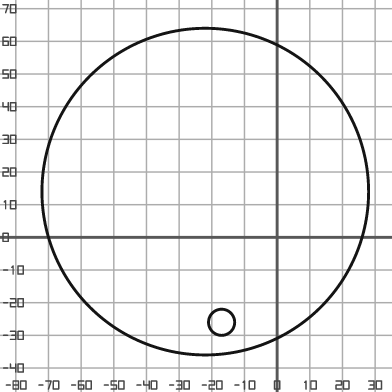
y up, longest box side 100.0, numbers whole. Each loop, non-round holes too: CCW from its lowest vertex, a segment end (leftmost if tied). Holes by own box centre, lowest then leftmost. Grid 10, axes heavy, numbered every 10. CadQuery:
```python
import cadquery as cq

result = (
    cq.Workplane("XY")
    .moveTo(-22.0, 14.0)
    .circle(50.0)
    .moveTo(-17.0, -26.0)
    .circle(4.0)
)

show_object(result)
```